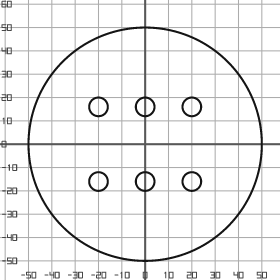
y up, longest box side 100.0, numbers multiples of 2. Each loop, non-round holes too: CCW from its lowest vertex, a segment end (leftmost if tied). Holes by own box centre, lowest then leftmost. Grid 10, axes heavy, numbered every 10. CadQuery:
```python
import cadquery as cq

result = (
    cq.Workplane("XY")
    .moveTo(0.0, 0.0)
    .circle(50.0)
    .moveTo(-20.0, -16.0)
    .circle(4.0)
    .moveTo(0.0, -16.0)
    .circle(4.0)
    .moveTo(20.0, -16.0)
    .circle(4.0)
    .moveTo(-20.0, 16.0)
    .circle(4.0)
    .moveTo(0.0, 16.0)
    .circle(4.0)
    .moveTo(20.0, 16.0)
    .circle(4.0)
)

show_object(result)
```